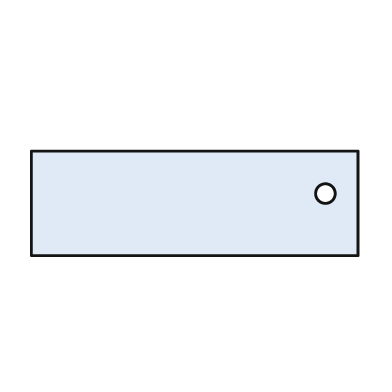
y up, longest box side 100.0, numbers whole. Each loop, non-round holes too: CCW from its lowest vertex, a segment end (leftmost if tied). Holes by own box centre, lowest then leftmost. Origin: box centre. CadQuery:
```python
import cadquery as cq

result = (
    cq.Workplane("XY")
    .moveTo(-50.0, -16.0)
    .lineTo(50.0, -16.0)
    .lineTo(50.0, 16.0)
    .lineTo(-50.0, 16.0)
    .close()
    .moveTo(40.0, 3.0)
    .circle(3.0)
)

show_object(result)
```